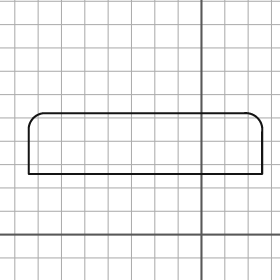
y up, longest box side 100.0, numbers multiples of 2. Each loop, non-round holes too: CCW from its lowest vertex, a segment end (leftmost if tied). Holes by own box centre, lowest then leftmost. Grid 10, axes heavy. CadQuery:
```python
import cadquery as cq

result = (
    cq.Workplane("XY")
    .moveTo(-74.0, 26.0)
    .lineTo(26.0, 26.0)
    .lineTo(26.0, 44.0)
    .threePointArc((24.0, 50.0), (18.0, 52.0))
    .lineTo(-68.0, 52.0)
    .threePointArc((-72.0, 50.0), (-74.0, 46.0))
    .close()
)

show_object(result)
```